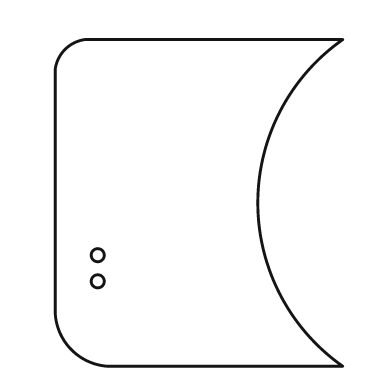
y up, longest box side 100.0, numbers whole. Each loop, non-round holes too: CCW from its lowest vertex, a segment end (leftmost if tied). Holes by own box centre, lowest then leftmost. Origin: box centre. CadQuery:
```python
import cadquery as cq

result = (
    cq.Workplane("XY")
    .moveTo(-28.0, -50.0)
    .lineTo(44.0, -50.0)
    .threePointArc((18.0, 0.0), (44.0, 50.0))
    .lineTo(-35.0, 50.0)
    .threePointArc((-41.0, 47.0), (-44.0, 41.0))
    .lineTo(-44.0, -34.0)
    .threePointArc((-39.0, -45.0), (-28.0, -50.0))
    .close()
    .moveTo(-31.0, -24.0)
    .circle(2.0)
    .moveTo(-31.0, -16.0)
    .circle(2.0)
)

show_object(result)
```